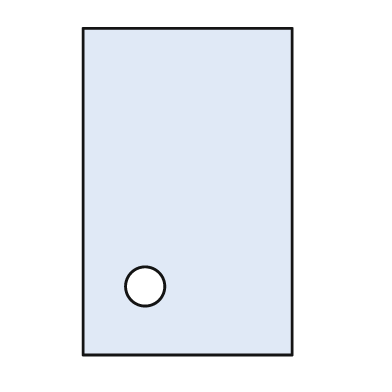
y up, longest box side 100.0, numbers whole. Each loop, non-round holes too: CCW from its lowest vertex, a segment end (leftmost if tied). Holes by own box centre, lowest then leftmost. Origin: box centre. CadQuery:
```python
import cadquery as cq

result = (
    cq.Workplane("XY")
    .moveTo(-32.0, -50.0)
    .lineTo(32.0, -50.0)
    .lineTo(32.0, 50.0)
    .lineTo(-32.0, 50.0)
    .close()
    .moveTo(-13.0, -29.0)
    .circle(6.0)
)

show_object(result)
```